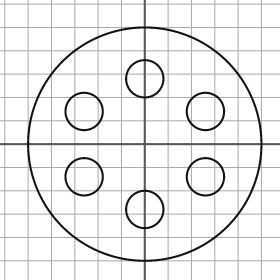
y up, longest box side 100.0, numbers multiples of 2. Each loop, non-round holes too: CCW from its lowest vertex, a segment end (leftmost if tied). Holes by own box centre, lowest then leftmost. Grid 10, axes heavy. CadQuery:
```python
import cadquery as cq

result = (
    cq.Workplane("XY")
    .moveTo(0.0, 0.0)
    .circle(50.0)
    .moveTo(0.0, -28.0)
    .circle(8.0)
    .moveTo(-26.0, -14.0)
    .circle(8.0)
    .moveTo(26.0, -14.0)
    .circle(8.0)
    .moveTo(-26.0, 14.0)
    .circle(8.0)
    .moveTo(26.0, 14.0)
    .circle(8.0)
    .moveTo(0.0, 28.0)
    .circle(8.0)
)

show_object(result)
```